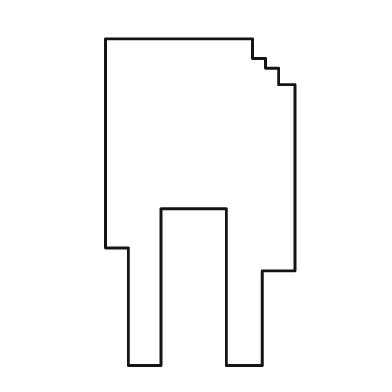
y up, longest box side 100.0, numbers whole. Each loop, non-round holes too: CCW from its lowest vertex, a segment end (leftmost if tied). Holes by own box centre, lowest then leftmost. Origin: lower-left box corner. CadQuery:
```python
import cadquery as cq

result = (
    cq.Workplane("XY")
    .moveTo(7.0, 0.0)
    .lineTo(17.0, 0.0)
    .lineTo(17.0, 48.0)
    .lineTo(37.0, 48.0)
    .lineTo(37.0, 0.0)
    .lineTo(48.0, 0.0)
    .lineTo(48.0, 29.0)
    .lineTo(58.0, 29.0)
    .lineTo(58.0, 86.0)
    .lineTo(53.0, 86.0)
    .lineTo(53.0, 91.0)
    .lineTo(49.0, 91.0)
    .lineTo(49.0, 94.0)
    .lineTo(45.0, 94.0)
    .lineTo(45.0, 100.0)
    .lineTo(0.0, 100.0)
    .lineTo(0.0, 36.0)
    .lineTo(7.0, 36.0)
    .close()
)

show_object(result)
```